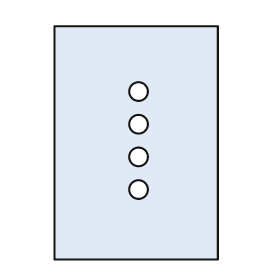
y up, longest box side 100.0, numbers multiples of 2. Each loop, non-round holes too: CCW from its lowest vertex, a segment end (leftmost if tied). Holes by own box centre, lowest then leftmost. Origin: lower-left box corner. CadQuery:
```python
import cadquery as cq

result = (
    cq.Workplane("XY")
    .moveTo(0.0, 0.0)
    .lineTo(70.0, 0.0)
    .lineTo(70.0, 100.0)
    .lineTo(0.0, 100.0)
    .close()
    .moveTo(36.0, 30.0)
    .circle(4.0)
    .moveTo(36.0, 44.0)
    .circle(4.0)
    .moveTo(36.0, 58.0)
    .circle(4.0)
    .moveTo(36.0, 72.0)
    .circle(4.0)
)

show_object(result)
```